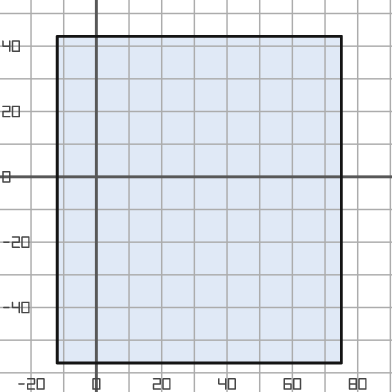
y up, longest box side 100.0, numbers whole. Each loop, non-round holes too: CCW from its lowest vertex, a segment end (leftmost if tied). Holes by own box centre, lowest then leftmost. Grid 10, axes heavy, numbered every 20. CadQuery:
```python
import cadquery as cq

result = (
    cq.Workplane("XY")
    .moveTo(-12.0, -57.0)
    .lineTo(75.0, -57.0)
    .lineTo(75.0, 43.0)
    .lineTo(-12.0, 43.0)
    .close()
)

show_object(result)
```